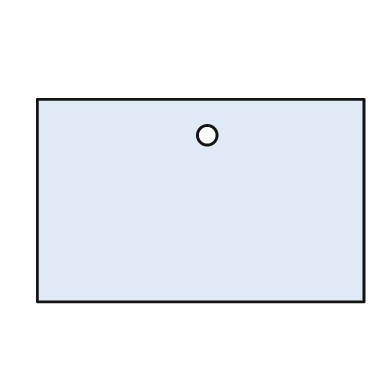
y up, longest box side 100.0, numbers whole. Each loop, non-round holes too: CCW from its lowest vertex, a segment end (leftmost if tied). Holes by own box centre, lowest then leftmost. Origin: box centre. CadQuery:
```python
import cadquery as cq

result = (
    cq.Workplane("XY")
    .moveTo(-50.0, -31.0)
    .lineTo(50.0, -31.0)
    .lineTo(50.0, 31.0)
    .lineTo(-50.0, 31.0)
    .close()
    .moveTo(2.0, 20.0)
    .circle(3.0)
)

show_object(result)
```